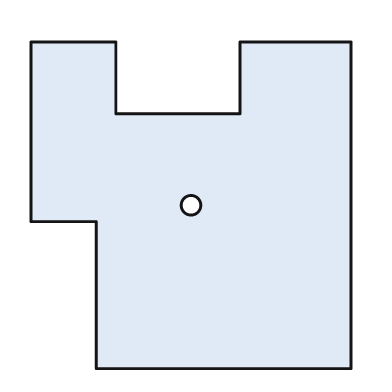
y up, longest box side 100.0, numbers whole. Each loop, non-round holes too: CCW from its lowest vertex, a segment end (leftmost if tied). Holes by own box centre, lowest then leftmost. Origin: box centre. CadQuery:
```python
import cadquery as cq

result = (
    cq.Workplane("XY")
    .moveTo(-29.0, -50.0)
    .lineTo(49.0, -50.0)
    .lineTo(49.0, 50.0)
    .lineTo(15.0, 50.0)
    .lineTo(15.0, 28.0)
    .lineTo(-23.0, 28.0)
    .lineTo(-23.0, 50.0)
    .lineTo(-49.0, 50.0)
    .lineTo(-49.0, -5.0)
    .lineTo(-29.0, -5.0)
    .close()
    .moveTo(0.0, 0.0)
    .circle(3.0)
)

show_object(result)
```